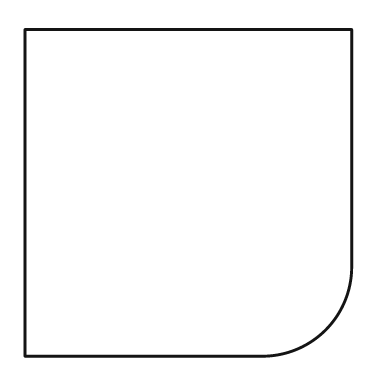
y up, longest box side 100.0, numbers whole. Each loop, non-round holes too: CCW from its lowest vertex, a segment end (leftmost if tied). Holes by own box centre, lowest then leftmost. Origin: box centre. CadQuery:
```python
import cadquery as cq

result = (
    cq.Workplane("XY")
    .moveTo(-50.0, -50.0)
    .lineTo(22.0, -50.0)
    .threePointArc((42.0, -42.0), (50.0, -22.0))
    .lineTo(50.0, 50.0)
    .lineTo(-50.0, 50.0)
    .close()
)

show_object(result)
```